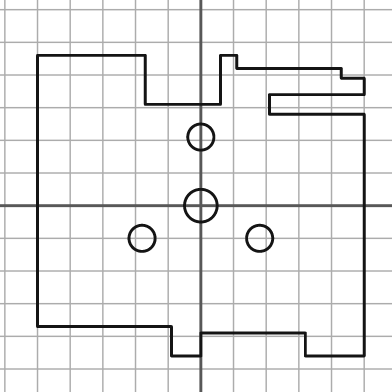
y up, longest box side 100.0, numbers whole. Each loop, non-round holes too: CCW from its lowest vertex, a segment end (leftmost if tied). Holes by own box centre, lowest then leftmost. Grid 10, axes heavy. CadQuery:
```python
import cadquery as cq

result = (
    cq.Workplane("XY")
    .moveTo(-9.0, -46.0)
    .lineTo(0.0, -46.0)
    .lineTo(0.0, -39.0)
    .lineTo(32.0, -39.0)
    .lineTo(32.0, -46.0)
    .lineTo(50.0, -46.0)
    .lineTo(50.0, 28.0)
    .lineTo(21.0, 28.0)
    .lineTo(21.0, 34.0)
    .lineTo(50.0, 34.0)
    .lineTo(50.0, 39.0)
    .lineTo(43.0, 39.0)
    .lineTo(43.0, 42.0)
    .lineTo(11.0, 42.0)
    .lineTo(11.0, 46.0)
    .lineTo(6.0, 46.0)
    .lineTo(6.0, 31.0)
    .lineTo(-17.0, 31.0)
    .lineTo(-17.0, 46.0)
    .lineTo(-50.0, 46.0)
    .lineTo(-50.0, -37.0)
    .lineTo(-9.0, -37.0)
    .close()
    .moveTo(-18.0, -10.0)
    .circle(4.0)
    .moveTo(18.0, -10.0)
    .circle(4.0)
    .moveTo(0.0, 0.0)
    .circle(5.0)
    .moveTo(0.0, 21.0)
    .circle(4.0)
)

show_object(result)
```